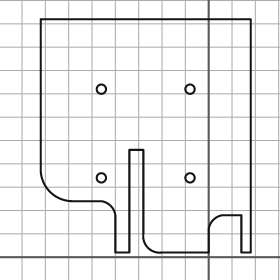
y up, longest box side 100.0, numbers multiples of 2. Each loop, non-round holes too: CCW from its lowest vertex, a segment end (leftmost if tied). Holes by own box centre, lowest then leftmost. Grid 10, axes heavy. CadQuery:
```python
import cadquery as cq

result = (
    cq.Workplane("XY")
    .moveTo(-40.0, 2.0)
    .lineTo(-34.0, 2.0)
    .lineTo(-34.0, 46.0)
    .lineTo(-28.0, 46.0)
    .lineTo(-28.0, 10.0)
    .threePointArc((-26.0, 4.0), (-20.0, 2.0))
    .lineTo(0.0, 2.0)
    .lineTo(0.0, 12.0)
    .threePointArc((2.0, 16.0), (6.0, 18.0))
    .lineTo(14.0, 18.0)
    .lineTo(14.0, 2.0)
    .lineTo(18.0, 2.0)
    .lineTo(18.0, 102.0)
    .lineTo(-72.0, 102.0)
    .lineTo(-72.0, 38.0)
    .threePointArc((-68.0, 28.0), (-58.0, 24.0))
    .lineTo(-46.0, 24.0)
    .threePointArc((-42.0, 22.0), (-40.0, 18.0))
    .close()
    .moveTo(-46.0, 34.0)
    .circle(2.0)
    .moveTo(-8.0, 34.0)
    .circle(2.0)
    .moveTo(-46.0, 72.0)
    .circle(2.0)
    .moveTo(-8.0, 72.0)
    .circle(2.0)
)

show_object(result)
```